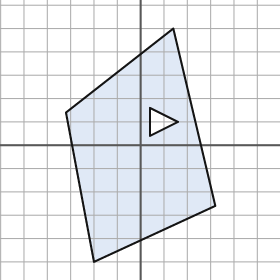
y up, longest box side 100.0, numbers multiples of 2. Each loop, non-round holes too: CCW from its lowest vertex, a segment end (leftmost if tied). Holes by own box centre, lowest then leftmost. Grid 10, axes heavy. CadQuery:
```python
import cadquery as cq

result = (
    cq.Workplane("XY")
    .moveTo(-20.0, -50.0)
    .lineTo(32.0, -26.0)
    .lineTo(14.0, 50.0)
    .lineTo(-32.0, 14.0)
    .close()
    .moveTo(4.0, 4.0)
    .lineTo(16.0, 10.0)
    .lineTo(4.0, 16.0)
    .close()
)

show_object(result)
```